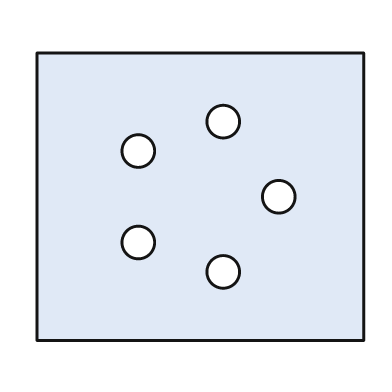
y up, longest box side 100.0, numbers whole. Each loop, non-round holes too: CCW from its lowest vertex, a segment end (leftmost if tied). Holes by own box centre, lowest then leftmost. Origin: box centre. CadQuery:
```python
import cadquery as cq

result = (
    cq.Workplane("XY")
    .moveTo(-50.0, -44.0)
    .lineTo(50.0, -44.0)
    .lineTo(50.0, 44.0)
    .lineTo(-50.0, 44.0)
    .close()
    .moveTo(7.0, -23.0)
    .circle(5.0)
    .moveTo(-19.0, -14.0)
    .circle(5.0)
    .moveTo(24.0, 0.0)
    .circle(5.0)
    .moveTo(-19.0, 14.0)
    .circle(5.0)
    .moveTo(7.0, 23.0)
    .circle(5.0)
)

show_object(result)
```